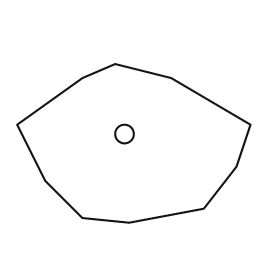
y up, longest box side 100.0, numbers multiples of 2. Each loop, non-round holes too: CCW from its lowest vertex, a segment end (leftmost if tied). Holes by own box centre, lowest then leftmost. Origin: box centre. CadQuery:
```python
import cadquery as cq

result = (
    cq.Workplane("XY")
    .moveTo(-2.0, -34.0)
    .lineTo(30.0, -28.0)
    .lineTo(44.0, -10.0)
    .lineTo(50.0, 8.0)
    .lineTo(16.0, 28.0)
    .lineTo(-8.0, 34.0)
    .lineTo(-22.0, 28.0)
    .lineTo(-50.0, 8.0)
    .lineTo(-38.0, -16.0)
    .lineTo(-22.0, -32.0)
    .close()
    .moveTo(-4.0, 4.0)
    .circle(4.0)
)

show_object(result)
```